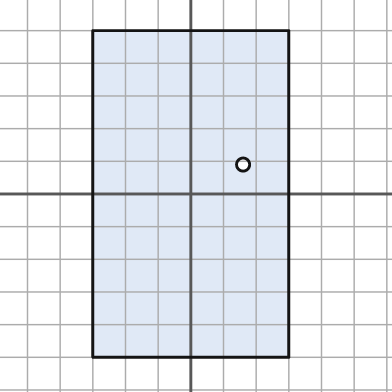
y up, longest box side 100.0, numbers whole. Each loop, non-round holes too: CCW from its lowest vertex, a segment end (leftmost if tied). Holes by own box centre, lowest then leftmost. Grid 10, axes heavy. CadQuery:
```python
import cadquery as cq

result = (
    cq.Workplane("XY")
    .moveTo(-30.0, -50.0)
    .lineTo(30.0, -50.0)
    .lineTo(30.0, 50.0)
    .lineTo(-30.0, 50.0)
    .close()
    .moveTo(16.0, 9.0)
    .circle(2.0)
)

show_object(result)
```